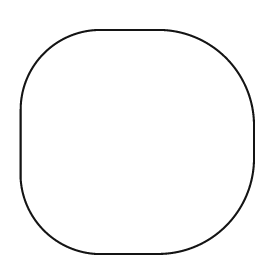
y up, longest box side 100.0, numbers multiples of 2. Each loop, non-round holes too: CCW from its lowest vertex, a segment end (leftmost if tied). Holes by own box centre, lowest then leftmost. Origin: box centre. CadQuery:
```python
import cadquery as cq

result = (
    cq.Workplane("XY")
    .moveTo(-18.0, -48.0)
    .lineTo(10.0, -48.0)
    .threePointArc((38.0, -36.0), (50.0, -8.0))
    .lineTo(50.0, 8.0)
    .threePointArc((38.0, 36.0), (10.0, 48.0))
    .lineTo(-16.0, 48.0)
    .threePointArc((-40.0, 38.0), (-50.0, 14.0))
    .lineTo(-50.0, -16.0)
    .threePointArc((-40.0, -38.0), (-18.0, -48.0))
    .close()
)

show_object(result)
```